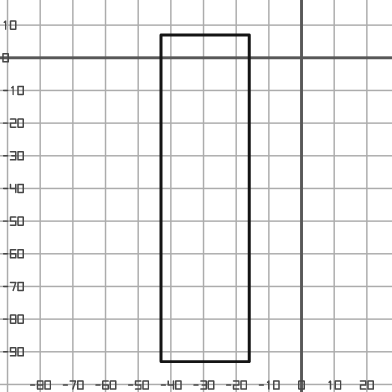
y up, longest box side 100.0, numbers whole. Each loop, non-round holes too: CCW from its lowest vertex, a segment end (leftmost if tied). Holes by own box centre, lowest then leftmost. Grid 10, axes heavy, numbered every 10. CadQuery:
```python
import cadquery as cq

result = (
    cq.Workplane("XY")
    .moveTo(-43.0, -93.0)
    .lineTo(-16.0, -93.0)
    .lineTo(-16.0, 7.0)
    .lineTo(-43.0, 7.0)
    .close()
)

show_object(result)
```